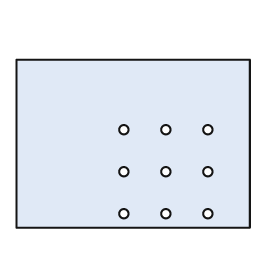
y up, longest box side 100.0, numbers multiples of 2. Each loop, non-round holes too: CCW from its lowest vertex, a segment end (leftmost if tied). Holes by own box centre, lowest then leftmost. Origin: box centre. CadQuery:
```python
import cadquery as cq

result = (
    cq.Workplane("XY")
    .moveTo(-50.0, -36.0)
    .lineTo(50.0, -36.0)
    .lineTo(50.0, 36.0)
    .lineTo(-50.0, 36.0)
    .close()
    .moveTo(-4.0, -30.0)
    .circle(2.0)
    .moveTo(14.0, -30.0)
    .circle(2.0)
    .moveTo(32.0, -30.0)
    .circle(2.0)
    .moveTo(-4.0, -12.0)
    .circle(2.0)
    .moveTo(14.0, -12.0)
    .circle(2.0)
    .moveTo(32.0, -12.0)
    .circle(2.0)
    .moveTo(-4.0, 6.0)
    .circle(2.0)
    .moveTo(14.0, 6.0)
    .circle(2.0)
    .moveTo(32.0, 6.0)
    .circle(2.0)
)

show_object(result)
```